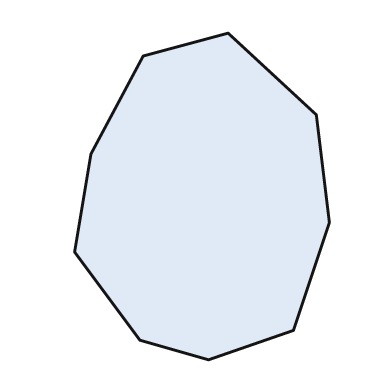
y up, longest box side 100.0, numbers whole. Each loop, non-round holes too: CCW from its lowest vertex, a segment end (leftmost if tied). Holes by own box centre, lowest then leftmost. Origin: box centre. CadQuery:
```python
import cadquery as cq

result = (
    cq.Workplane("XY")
    .moveTo(2.0, -50.0)
    .lineTo(28.0, -41.0)
    .lineTo(39.0, -8.0)
    .lineTo(35.0, 25.0)
    .lineTo(8.0, 50.0)
    .lineTo(-18.0, 43.0)
    .lineTo(-34.0, 13.0)
    .lineTo(-39.0, -17.0)
    .lineTo(-19.0, -44.0)
    .close()
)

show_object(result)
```